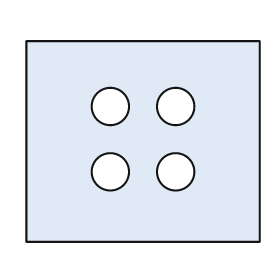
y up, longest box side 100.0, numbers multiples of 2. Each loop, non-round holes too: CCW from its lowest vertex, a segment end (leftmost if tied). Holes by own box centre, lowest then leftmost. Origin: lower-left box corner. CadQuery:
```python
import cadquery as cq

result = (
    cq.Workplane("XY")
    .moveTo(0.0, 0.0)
    .lineTo(100.0, 0.0)
    .lineTo(100.0, 86.0)
    .lineTo(0.0, 86.0)
    .close()
    .moveTo(36.0, 30.0)
    .circle(8.0)
    .moveTo(64.0, 30.0)
    .circle(8.0)
    .moveTo(36.0, 58.0)
    .circle(8.0)
    .moveTo(64.0, 58.0)
    .circle(8.0)
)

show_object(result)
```